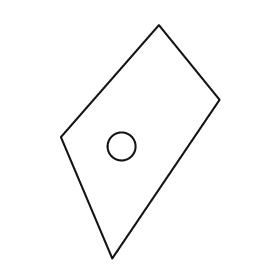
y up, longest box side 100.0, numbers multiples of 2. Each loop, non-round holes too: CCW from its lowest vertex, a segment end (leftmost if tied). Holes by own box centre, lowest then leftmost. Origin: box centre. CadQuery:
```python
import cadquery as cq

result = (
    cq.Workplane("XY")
    .moveTo(-12.0, -50.0)
    .lineTo(34.0, 18.0)
    .lineTo(8.0, 50.0)
    .lineTo(-34.0, 2.0)
    .close()
    .moveTo(-8.0, -2.0)
    .circle(6.0)
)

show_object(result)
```